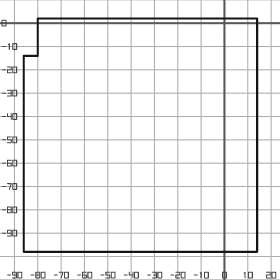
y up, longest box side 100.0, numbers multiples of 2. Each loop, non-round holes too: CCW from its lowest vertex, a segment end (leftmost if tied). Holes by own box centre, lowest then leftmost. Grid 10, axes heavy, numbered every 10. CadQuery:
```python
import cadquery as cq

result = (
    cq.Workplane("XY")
    .moveTo(-86.0, -98.0)
    .lineTo(14.0, -98.0)
    .lineTo(14.0, 2.0)
    .lineTo(-80.0, 2.0)
    .lineTo(-80.0, -14.0)
    .lineTo(-86.0, -14.0)
    .close()
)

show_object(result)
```